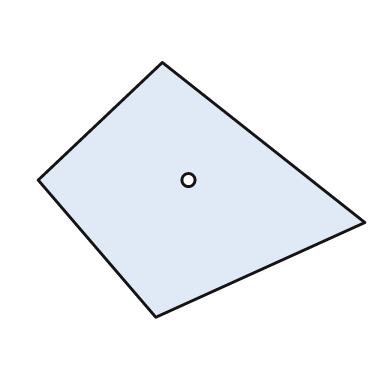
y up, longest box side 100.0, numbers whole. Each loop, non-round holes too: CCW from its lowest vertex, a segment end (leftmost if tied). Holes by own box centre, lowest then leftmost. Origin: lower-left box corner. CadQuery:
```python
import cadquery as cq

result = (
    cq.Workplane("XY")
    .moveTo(36.0, 0.0)
    .lineTo(100.0, 29.0)
    .lineTo(38.0, 78.0)
    .lineTo(0.0, 42.0)
    .close()
    .moveTo(46.0, 42.0)
    .circle(2.0)
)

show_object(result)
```